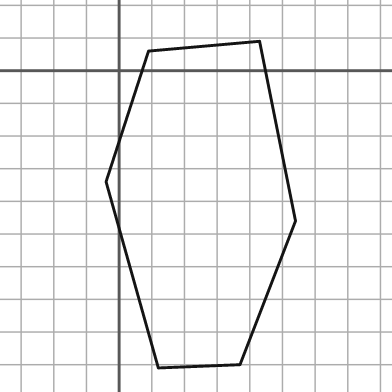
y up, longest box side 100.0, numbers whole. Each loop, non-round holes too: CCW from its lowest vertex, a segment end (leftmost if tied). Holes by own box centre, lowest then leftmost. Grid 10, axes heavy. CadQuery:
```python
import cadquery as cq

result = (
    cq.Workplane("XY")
    .moveTo(12.0, -91.0)
    .lineTo(37.0, -90.0)
    .lineTo(54.0, -46.0)
    .lineTo(43.0, 9.0)
    .lineTo(9.0, 6.0)
    .lineTo(-4.0, -34.0)
    .close()
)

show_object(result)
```